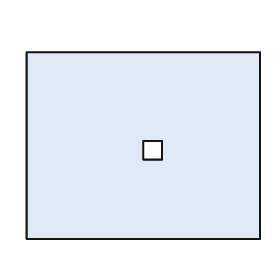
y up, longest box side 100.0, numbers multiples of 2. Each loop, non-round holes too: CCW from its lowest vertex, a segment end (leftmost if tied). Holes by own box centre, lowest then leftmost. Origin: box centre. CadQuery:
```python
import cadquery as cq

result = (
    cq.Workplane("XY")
    .moveTo(-50.0, -40.0)
    .lineTo(50.0, -40.0)
    .lineTo(50.0, 40.0)
    .lineTo(-50.0, 40.0)
    .close()
    .moveTo(0.0, -6.0)
    .lineTo(8.0, -6.0)
    .lineTo(8.0, 2.0)
    .lineTo(0.0, 2.0)
    .close()
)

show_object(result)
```